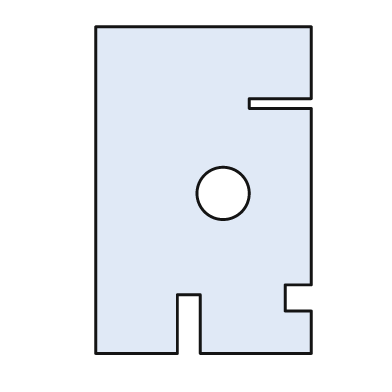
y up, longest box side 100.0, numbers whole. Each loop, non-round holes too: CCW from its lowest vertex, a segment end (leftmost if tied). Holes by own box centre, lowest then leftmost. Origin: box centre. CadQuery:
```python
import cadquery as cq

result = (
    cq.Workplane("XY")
    .moveTo(-33.0, -50.0)
    .lineTo(-8.0, -50.0)
    .lineTo(-8.0, -32.0)
    .lineTo(-1.0, -32.0)
    .lineTo(-1.0, -50.0)
    .lineTo(33.0, -50.0)
    .lineTo(33.0, -37.0)
    .lineTo(25.0, -37.0)
    .lineTo(25.0, -29.0)
    .lineTo(33.0, -29.0)
    .lineTo(33.0, 25.0)
    .lineTo(14.0, 25.0)
    .lineTo(14.0, 28.0)
    .lineTo(33.0, 28.0)
    .lineTo(33.0, 50.0)
    .lineTo(-33.0, 50.0)
    .close()
    .moveTo(6.0, -1.0)
    .circle(8.0)
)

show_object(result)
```